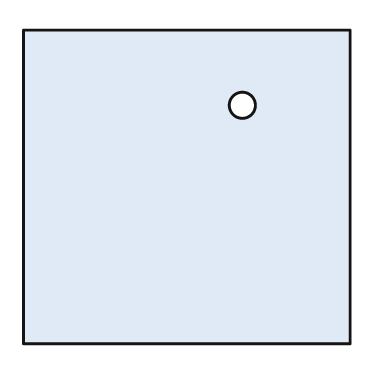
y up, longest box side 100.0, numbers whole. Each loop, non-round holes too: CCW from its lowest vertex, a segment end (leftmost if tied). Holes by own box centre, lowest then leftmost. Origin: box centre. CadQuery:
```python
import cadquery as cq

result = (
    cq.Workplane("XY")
    .moveTo(-50.0, -48.0)
    .lineTo(50.0, -48.0)
    .lineTo(50.0, 48.0)
    .lineTo(-50.0, 48.0)
    .close()
    .moveTo(17.0, 25.0)
    .circle(4.0)
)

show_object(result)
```